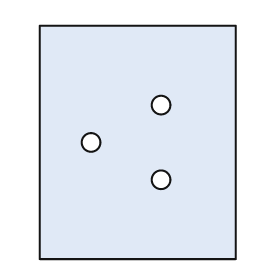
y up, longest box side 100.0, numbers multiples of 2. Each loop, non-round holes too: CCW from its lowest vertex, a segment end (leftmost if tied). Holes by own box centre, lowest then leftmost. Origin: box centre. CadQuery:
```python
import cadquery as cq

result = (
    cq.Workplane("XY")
    .moveTo(-42.0, -50.0)
    .lineTo(42.0, -50.0)
    .lineTo(42.0, 50.0)
    .lineTo(-42.0, 50.0)
    .close()
    .moveTo(10.0, -16.0)
    .circle(4.0)
    .moveTo(-20.0, 0.0)
    .circle(4.0)
    .moveTo(10.0, 16.0)
    .circle(4.0)
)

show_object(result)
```